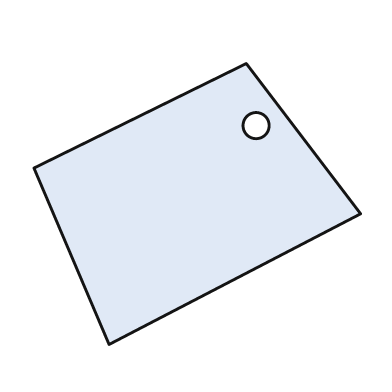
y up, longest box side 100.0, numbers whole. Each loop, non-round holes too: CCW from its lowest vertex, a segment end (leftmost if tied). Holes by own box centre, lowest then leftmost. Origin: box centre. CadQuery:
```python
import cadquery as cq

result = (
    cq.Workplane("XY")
    .moveTo(-27.0, -43.0)
    .lineTo(50.0, -3.0)
    .lineTo(15.0, 43.0)
    .lineTo(-50.0, 11.0)
    .close()
    .moveTo(18.0, 24.0)
    .circle(4.0)
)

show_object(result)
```